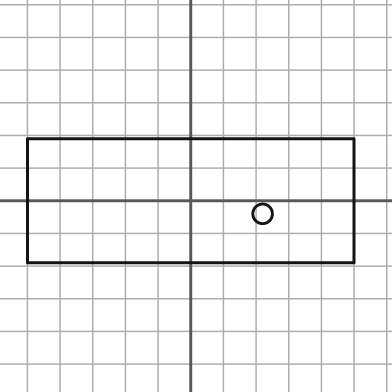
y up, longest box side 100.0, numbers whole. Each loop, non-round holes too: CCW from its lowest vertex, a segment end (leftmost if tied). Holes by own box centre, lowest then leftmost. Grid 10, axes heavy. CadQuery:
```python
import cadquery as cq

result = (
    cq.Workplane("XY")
    .moveTo(-50.0, -19.0)
    .lineTo(50.0, -19.0)
    .lineTo(50.0, 19.0)
    .lineTo(-50.0, 19.0)
    .close()
    .moveTo(22.0, -4.0)
    .circle(3.0)
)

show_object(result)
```